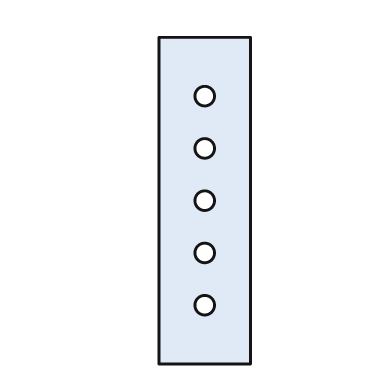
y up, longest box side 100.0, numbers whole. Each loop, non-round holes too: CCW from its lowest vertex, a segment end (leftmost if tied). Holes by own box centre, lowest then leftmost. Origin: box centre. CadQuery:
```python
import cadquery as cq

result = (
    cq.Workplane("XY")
    .moveTo(-14.0, -50.0)
    .lineTo(14.0, -50.0)
    .lineTo(14.0, 50.0)
    .lineTo(-14.0, 50.0)
    .close()
    .moveTo(0.0, -32.0)
    .circle(3.0)
    .moveTo(0.0, -16.0)
    .circle(3.0)
    .moveTo(0.0, 0.0)
    .circle(3.0)
    .moveTo(0.0, 16.0)
    .circle(3.0)
    .moveTo(0.0, 32.0)
    .circle(3.0)
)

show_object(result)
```